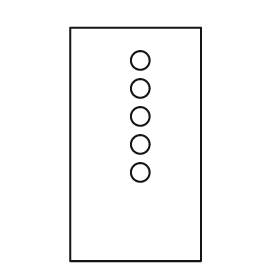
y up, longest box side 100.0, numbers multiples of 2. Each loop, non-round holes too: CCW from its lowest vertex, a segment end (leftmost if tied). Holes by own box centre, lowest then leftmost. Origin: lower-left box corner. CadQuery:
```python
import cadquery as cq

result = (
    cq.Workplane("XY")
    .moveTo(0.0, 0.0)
    .lineTo(56.0, 0.0)
    .lineTo(56.0, 100.0)
    .lineTo(0.0, 100.0)
    .close()
    .moveTo(30.0, 38.0)
    .circle(4.0)
    .moveTo(30.0, 50.0)
    .circle(4.0)
    .moveTo(30.0, 62.0)
    .circle(4.0)
    .moveTo(30.0, 74.0)
    .circle(4.0)
    .moveTo(30.0, 86.0)
    .circle(4.0)
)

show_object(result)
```